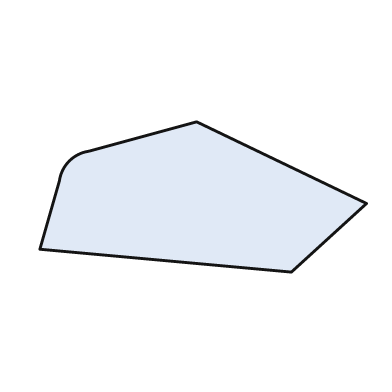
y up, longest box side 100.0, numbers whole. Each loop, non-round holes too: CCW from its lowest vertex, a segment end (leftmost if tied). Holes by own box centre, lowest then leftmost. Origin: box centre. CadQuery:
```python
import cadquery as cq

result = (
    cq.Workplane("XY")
    .moveTo(27.0, -23.0)
    .lineTo(50.0, -2.0)
    .lineTo(-2.0, 23.0)
    .lineTo(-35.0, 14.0)
    .threePointArc((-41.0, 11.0), (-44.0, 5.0))
    .lineTo(-50.0, -16.0)
    .close()
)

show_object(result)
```